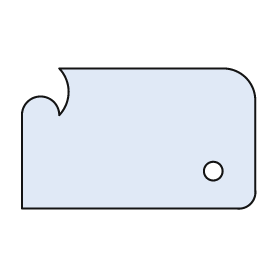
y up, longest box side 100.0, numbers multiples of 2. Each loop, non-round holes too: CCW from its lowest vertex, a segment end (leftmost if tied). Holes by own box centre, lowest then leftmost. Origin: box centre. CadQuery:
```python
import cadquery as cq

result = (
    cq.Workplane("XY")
    .moveTo(-50.0, -30.0)
    .lineTo(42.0, -30.0)
    .threePointArc((48.0, -28.0), (50.0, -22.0))
    .lineTo(50.0, 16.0)
    .threePointArc((46.0, 26.0), (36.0, 30.0))
    .lineTo(-34.0, 30.0)
    .threePointArc((-30.0, 20.0), (-34.0, 10.0))
    .threePointArc((-42.0, 18.0), (-50.0, 10.0))
    .close()
    .moveTo(32.0, -14.0)
    .circle(4.0)
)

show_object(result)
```